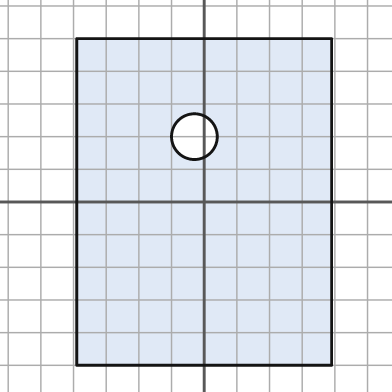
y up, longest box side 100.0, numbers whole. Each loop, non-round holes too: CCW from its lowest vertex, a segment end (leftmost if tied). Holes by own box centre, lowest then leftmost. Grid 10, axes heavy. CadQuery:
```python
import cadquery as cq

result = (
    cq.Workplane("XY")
    .moveTo(-39.0, -50.0)
    .lineTo(39.0, -50.0)
    .lineTo(39.0, 50.0)
    .lineTo(-39.0, 50.0)
    .close()
    .moveTo(-3.0, 20.0)
    .circle(7.0)
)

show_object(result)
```